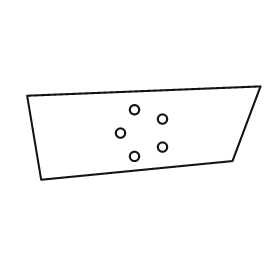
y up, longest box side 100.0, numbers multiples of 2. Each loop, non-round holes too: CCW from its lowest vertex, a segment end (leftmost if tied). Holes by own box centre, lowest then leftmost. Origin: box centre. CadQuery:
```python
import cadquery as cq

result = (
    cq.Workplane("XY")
    .moveTo(-44.0, -20.0)
    .lineTo(38.0, -12.0)
    .lineTo(50.0, 20.0)
    .lineTo(-50.0, 16.0)
    .close()
    .moveTo(-4.0, -10.0)
    .circle(2.0)
    .moveTo(8.0, -6.0)
    .circle(2.0)
    .moveTo(-10.0, 0.0)
    .circle(2.0)
    .moveTo(8.0, 6.0)
    .circle(2.0)
    .moveTo(-4.0, 10.0)
    .circle(2.0)
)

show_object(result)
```